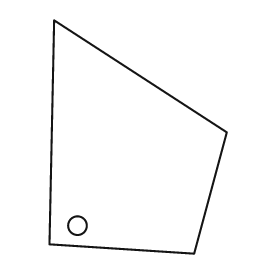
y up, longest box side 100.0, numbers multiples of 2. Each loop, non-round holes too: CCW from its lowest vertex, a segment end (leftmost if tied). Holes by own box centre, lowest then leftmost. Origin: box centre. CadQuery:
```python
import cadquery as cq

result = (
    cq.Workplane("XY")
    .moveTo(24.0, -50.0)
    .lineTo(38.0, 2.0)
    .lineTo(-36.0, 50.0)
    .lineTo(-38.0, -46.0)
    .close()
    .moveTo(-26.0, -38.0)
    .circle(4.0)
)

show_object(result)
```